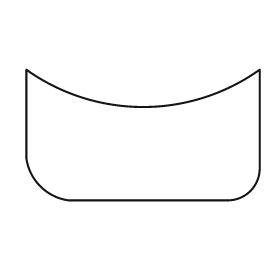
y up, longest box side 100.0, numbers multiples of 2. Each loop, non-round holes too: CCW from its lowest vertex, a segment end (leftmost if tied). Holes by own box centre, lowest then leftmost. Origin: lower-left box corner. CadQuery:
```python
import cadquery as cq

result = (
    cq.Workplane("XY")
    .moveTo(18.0, 0.0)
    .lineTo(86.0, 0.0)
    .threePointArc((96.0, 4.0), (100.0, 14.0))
    .lineTo(100.0, 56.0)
    .threePointArc((50.0, 40.0), (0.0, 56.0))
    .lineTo(0.0, 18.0)
    .threePointArc((6.0, 6.0), (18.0, 0.0))
    .close()
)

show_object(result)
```